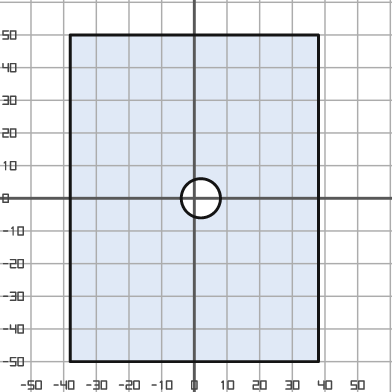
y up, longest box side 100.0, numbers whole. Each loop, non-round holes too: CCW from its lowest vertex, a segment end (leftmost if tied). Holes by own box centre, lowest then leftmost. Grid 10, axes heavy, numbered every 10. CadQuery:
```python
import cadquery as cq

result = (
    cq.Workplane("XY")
    .moveTo(-38.0, -50.0)
    .lineTo(38.0, -50.0)
    .lineTo(38.0, 50.0)
    .lineTo(-38.0, 50.0)
    .close()
    .moveTo(2.0, 0.0)
    .circle(6.0)
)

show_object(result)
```